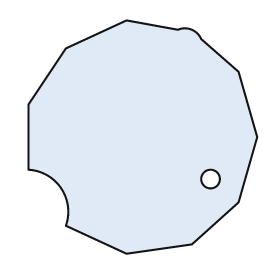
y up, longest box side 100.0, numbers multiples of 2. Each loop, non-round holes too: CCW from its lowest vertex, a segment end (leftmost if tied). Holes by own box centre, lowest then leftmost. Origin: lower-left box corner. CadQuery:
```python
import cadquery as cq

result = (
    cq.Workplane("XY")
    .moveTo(42.0, 0.0)
    .lineTo(70.0, 4.0)
    .lineTo(90.0, 22.0)
    .lineTo(98.0, 50.0)
    .lineTo(90.0, 78.0)
    .lineTo(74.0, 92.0)
    .threePointArc((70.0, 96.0), (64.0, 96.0))
    .lineTo(42.0, 100.0)
    .lineTo(16.0, 88.0)
    .lineTo(0.0, 64.0)
    .lineTo(0.0, 36.0)
    .threePointArc((14.0, 28.0), (16.0, 12.0))
    .close()
    .moveTo(78.0, 32.0)
    .circle(4.0)
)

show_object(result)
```